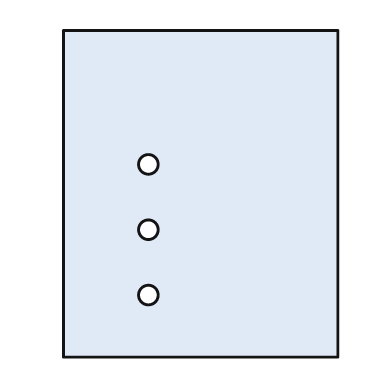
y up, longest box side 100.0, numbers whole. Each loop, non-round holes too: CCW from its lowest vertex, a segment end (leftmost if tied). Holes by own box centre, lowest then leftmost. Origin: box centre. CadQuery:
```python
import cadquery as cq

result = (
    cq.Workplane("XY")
    .moveTo(-42.0, -50.0)
    .lineTo(42.0, -50.0)
    .lineTo(42.0, 50.0)
    .lineTo(-42.0, 50.0)
    .close()
    .moveTo(-16.0, -31.0)
    .circle(3.0)
    .moveTo(-16.0, -11.0)
    .circle(3.0)
    .moveTo(-16.0, 9.0)
    .circle(3.0)
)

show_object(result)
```